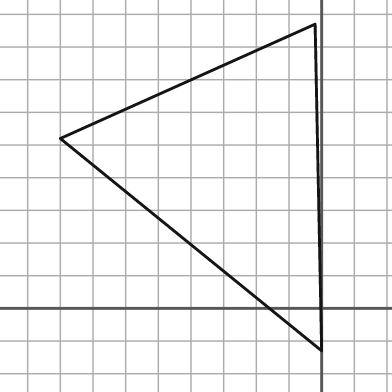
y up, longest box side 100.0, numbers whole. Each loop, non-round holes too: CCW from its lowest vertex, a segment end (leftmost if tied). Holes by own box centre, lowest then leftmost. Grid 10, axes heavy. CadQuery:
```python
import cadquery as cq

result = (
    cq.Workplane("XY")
    .moveTo(0.0, -13.0)
    .lineTo(-2.0, 87.0)
    .lineTo(-80.0, 52.0)
    .close()
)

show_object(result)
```